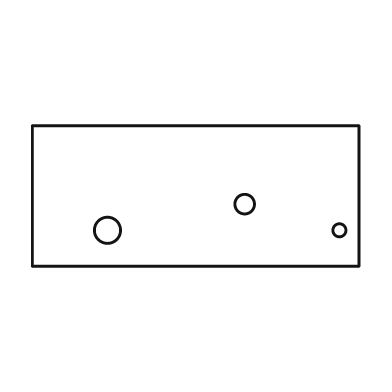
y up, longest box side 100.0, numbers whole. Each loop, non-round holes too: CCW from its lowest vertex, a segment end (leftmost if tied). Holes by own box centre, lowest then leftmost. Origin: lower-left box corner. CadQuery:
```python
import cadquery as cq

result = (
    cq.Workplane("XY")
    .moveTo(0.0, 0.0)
    .lineTo(100.0, 0.0)
    .lineTo(100.0, 43.0)
    .lineTo(0.0, 43.0)
    .close()
    .moveTo(23.0, 11.0)
    .circle(4.0)
    .moveTo(94.0, 11.0)
    .circle(2.0)
    .moveTo(65.0, 19.0)
    .circle(3.0)
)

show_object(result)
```